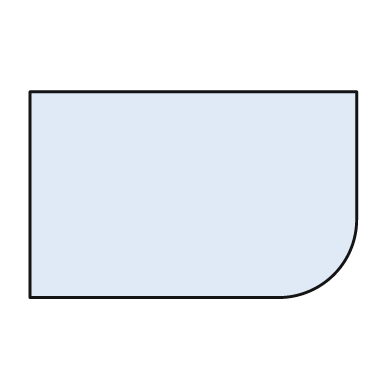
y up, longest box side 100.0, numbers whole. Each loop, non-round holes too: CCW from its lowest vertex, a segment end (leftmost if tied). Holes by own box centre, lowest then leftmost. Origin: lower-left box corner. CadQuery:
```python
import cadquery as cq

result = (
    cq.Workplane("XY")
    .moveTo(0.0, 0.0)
    .lineTo(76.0, 0.0)
    .threePointArc((93.0, 7.0), (100.0, 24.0))
    .lineTo(100.0, 63.0)
    .lineTo(0.0, 63.0)
    .close()
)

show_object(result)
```